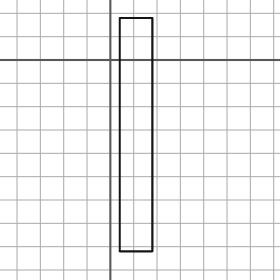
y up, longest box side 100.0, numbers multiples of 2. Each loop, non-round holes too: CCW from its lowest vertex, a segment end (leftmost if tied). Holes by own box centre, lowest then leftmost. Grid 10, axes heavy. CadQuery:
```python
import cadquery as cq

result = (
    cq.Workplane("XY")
    .moveTo(4.0, -82.0)
    .lineTo(18.0, -82.0)
    .lineTo(18.0, 18.0)
    .lineTo(4.0, 18.0)
    .close()
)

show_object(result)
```